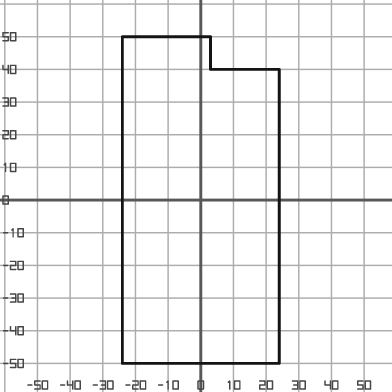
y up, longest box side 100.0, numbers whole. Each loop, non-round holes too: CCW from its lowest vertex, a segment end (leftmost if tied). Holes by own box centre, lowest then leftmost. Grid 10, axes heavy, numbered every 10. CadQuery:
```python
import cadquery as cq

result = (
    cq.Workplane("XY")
    .moveTo(-24.0, -50.0)
    .lineTo(24.0, -50.0)
    .lineTo(24.0, 40.0)
    .lineTo(3.0, 40.0)
    .lineTo(3.0, 50.0)
    .lineTo(-24.0, 50.0)
    .close()
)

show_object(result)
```